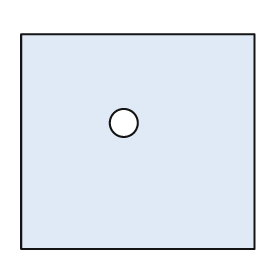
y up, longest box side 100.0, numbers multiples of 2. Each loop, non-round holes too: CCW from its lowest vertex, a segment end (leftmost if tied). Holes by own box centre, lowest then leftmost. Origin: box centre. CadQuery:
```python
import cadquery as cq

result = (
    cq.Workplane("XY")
    .moveTo(-50.0, -46.0)
    .lineTo(50.0, -46.0)
    .lineTo(50.0, 46.0)
    .lineTo(-50.0, 46.0)
    .close()
    .moveTo(-6.0, 8.0)
    .circle(6.0)
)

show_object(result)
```